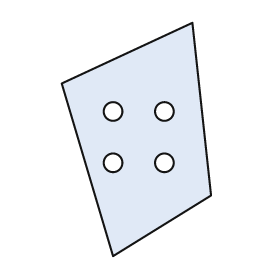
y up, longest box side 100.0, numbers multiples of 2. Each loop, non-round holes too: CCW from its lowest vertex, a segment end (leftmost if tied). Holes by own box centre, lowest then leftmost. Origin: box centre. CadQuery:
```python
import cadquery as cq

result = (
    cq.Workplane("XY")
    .moveTo(-10.0, -50.0)
    .lineTo(32.0, -24.0)
    .lineTo(24.0, 50.0)
    .lineTo(-32.0, 24.0)
    .close()
    .moveTo(-10.0, -10.0)
    .circle(4.0)
    .moveTo(12.0, -10.0)
    .circle(4.0)
    .moveTo(-10.0, 12.0)
    .circle(4.0)
    .moveTo(12.0, 12.0)
    .circle(4.0)
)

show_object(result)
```